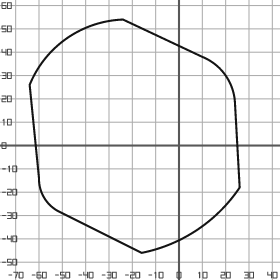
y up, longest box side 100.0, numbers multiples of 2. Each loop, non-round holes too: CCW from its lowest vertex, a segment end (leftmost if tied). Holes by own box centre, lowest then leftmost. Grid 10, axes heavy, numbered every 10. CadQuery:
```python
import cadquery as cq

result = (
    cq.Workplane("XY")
    .moveTo(-16.0, -46.0)
    .threePointArc((8.0, -36.0), (26.0, -18.0))
    .lineTo(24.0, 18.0)
    .threePointArc((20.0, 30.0), (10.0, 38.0))
    .lineTo(-24.0, 54.0)
    .threePointArc((-48.0, 46.0), (-64.0, 26.0))
    .lineTo(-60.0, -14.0)
    .threePointArc((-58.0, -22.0), (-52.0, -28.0))
    .close()
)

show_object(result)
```